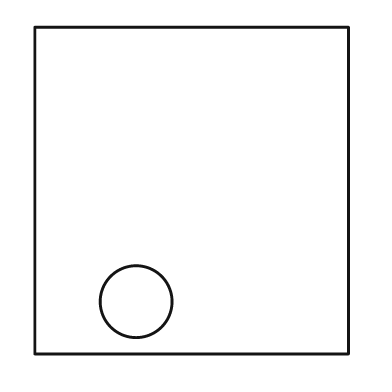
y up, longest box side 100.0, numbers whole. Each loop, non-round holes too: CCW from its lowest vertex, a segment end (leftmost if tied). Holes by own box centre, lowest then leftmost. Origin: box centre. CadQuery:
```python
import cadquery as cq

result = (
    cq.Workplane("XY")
    .moveTo(-48.0, -50.0)
    .lineTo(48.0, -50.0)
    .lineTo(48.0, 50.0)
    .lineTo(-48.0, 50.0)
    .close()
    .moveTo(-17.0, -34.0)
    .circle(11.0)
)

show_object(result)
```